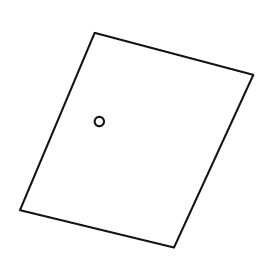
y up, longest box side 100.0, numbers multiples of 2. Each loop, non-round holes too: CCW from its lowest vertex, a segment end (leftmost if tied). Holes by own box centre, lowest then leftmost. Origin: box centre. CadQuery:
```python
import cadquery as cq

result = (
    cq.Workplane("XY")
    .moveTo(16.0, -46.0)
    .lineTo(50.0, 28.0)
    .lineTo(-18.0, 46.0)
    .lineTo(-50.0, -30.0)
    .close()
    .moveTo(-16.0, 8.0)
    .circle(2.0)
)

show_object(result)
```